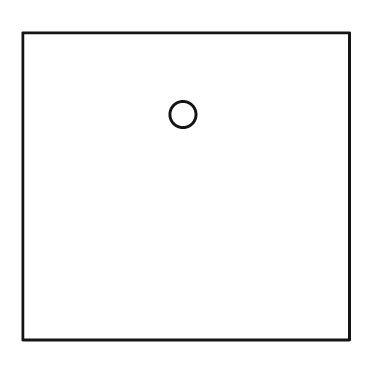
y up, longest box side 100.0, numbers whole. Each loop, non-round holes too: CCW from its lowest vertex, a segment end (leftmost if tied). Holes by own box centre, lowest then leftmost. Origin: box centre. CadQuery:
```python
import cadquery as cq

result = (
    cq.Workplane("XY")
    .moveTo(-50.0, -47.0)
    .lineTo(50.0, -47.0)
    .lineTo(50.0, 47.0)
    .lineTo(-50.0, 47.0)
    .close()
    .moveTo(-1.0, 22.0)
    .circle(4.0)
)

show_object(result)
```